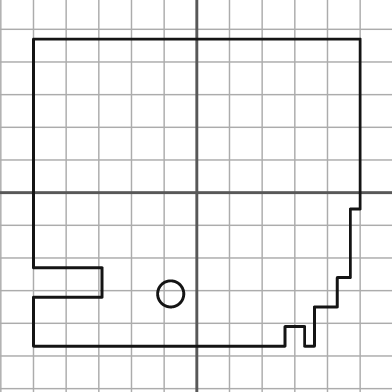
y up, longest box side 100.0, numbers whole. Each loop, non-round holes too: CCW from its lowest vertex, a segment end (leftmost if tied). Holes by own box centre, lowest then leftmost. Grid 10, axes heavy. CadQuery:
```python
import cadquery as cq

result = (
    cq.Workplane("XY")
    .moveTo(-50.0, -47.0)
    .lineTo(27.0, -47.0)
    .lineTo(27.0, -41.0)
    .lineTo(33.0, -41.0)
    .lineTo(33.0, -47.0)
    .lineTo(36.0, -47.0)
    .lineTo(36.0, -35.0)
    .lineTo(43.0, -35.0)
    .lineTo(43.0, -26.0)
    .lineTo(47.0, -26.0)
    .lineTo(47.0, -5.0)
    .lineTo(50.0, -5.0)
    .lineTo(50.0, 47.0)
    .lineTo(-50.0, 47.0)
    .lineTo(-50.0, -23.0)
    .lineTo(-29.0, -23.0)
    .lineTo(-29.0, -32.0)
    .lineTo(-50.0, -32.0)
    .close()
    .moveTo(-8.0, -31.0)
    .circle(4.0)
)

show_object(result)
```